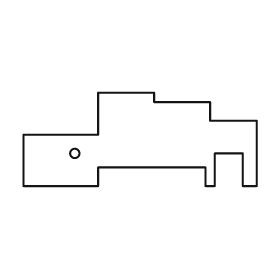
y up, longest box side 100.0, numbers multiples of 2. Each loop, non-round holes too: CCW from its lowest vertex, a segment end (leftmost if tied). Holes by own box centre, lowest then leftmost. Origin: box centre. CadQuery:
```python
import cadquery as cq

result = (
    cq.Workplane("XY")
    .moveTo(-50.0, -20.0)
    .lineTo(-18.0, -20.0)
    .lineTo(-18.0, -12.0)
    .lineTo(28.0, -12.0)
    .lineTo(28.0, -20.0)
    .lineTo(32.0, -20.0)
    .lineTo(32.0, -6.0)
    .lineTo(44.0, -6.0)
    .lineTo(44.0, -20.0)
    .lineTo(50.0, -20.0)
    .lineTo(50.0, 8.0)
    .lineTo(30.0, 8.0)
    .lineTo(30.0, 16.0)
    .lineTo(6.0, 16.0)
    .lineTo(6.0, 20.0)
    .lineTo(-18.0, 20.0)
    .lineTo(-18.0, 2.0)
    .lineTo(-50.0, 2.0)
    .close()
    .moveTo(-28.0, -6.0)
    .circle(2.0)
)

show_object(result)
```